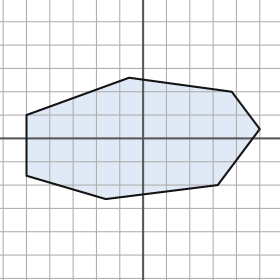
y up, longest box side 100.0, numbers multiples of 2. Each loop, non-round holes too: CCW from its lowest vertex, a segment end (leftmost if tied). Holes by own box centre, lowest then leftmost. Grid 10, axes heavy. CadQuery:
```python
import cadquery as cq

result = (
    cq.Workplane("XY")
    .moveTo(-16.0, -26.0)
    .lineTo(32.0, -20.0)
    .lineTo(50.0, 4.0)
    .lineTo(38.0, 20.0)
    .lineTo(-6.0, 26.0)
    .lineTo(-50.0, 10.0)
    .lineTo(-50.0, -16.0)
    .close()
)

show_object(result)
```